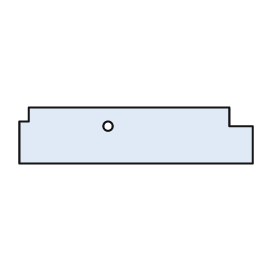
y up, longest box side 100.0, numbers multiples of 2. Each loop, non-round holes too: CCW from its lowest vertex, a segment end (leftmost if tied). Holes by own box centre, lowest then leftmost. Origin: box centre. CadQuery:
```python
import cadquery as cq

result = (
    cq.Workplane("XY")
    .moveTo(-50.0, -12.0)
    .lineTo(50.0, -12.0)
    .lineTo(50.0, 4.0)
    .lineTo(40.0, 4.0)
    .lineTo(40.0, 12.0)
    .lineTo(-46.0, 12.0)
    .lineTo(-46.0, 6.0)
    .lineTo(-50.0, 6.0)
    .close()
    .moveTo(-12.0, 4.0)
    .circle(2.0)
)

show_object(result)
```